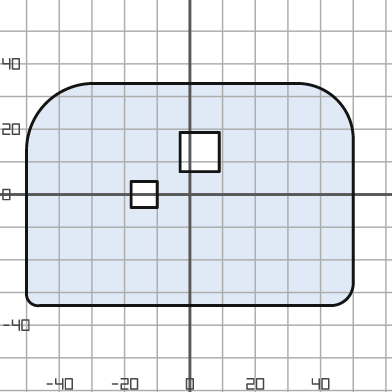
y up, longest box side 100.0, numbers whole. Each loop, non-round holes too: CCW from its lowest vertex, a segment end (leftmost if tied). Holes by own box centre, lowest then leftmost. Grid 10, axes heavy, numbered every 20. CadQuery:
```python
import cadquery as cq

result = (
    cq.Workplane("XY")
    .moveTo(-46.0, -34.0)
    .lineTo(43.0, -34.0)
    .threePointArc((48.0, -32.0), (50.0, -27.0))
    .lineTo(50.0, 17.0)
    .threePointArc((45.0, 29.0), (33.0, 34.0))
    .lineTo(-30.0, 34.0)
    .threePointArc((-44.0, 28.0), (-50.0, 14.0))
    .lineTo(-50.0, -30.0)
    .threePointArc((-49.0, -33.0), (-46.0, -34.0))
    .close()
    .moveTo(-18.0, -4.0)
    .lineTo(-10.0, -4.0)
    .lineTo(-10.0, 4.0)
    .lineTo(-18.0, 4.0)
    .close()
    .moveTo(-3.0, 7.0)
    .lineTo(9.0, 7.0)
    .lineTo(9.0, 19.0)
    .lineTo(-3.0, 19.0)
    .close()
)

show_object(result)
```